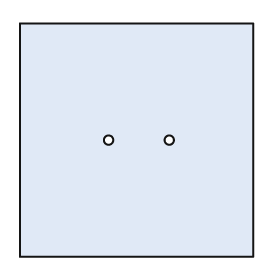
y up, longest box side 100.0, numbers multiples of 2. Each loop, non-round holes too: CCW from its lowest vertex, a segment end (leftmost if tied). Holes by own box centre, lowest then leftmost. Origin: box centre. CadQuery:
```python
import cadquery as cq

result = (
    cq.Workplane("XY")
    .moveTo(-50.0, -50.0)
    .lineTo(50.0, -50.0)
    .lineTo(50.0, 50.0)
    .lineTo(-50.0, 50.0)
    .close()
    .moveTo(-12.0, 0.0)
    .circle(2.0)
    .moveTo(14.0, 0.0)
    .circle(2.0)
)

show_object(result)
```